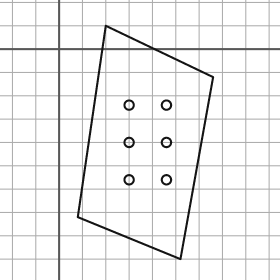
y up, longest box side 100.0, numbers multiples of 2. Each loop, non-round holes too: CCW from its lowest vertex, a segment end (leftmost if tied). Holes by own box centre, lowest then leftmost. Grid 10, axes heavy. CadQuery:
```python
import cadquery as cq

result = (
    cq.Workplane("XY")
    .moveTo(52.0, -90.0)
    .lineTo(66.0, -12.0)
    .lineTo(20.0, 10.0)
    .lineTo(8.0, -72.0)
    .close()
    .moveTo(30.0, -56.0)
    .circle(2.0)
    .moveTo(46.0, -56.0)
    .circle(2.0)
    .moveTo(30.0, -40.0)
    .circle(2.0)
    .moveTo(46.0, -40.0)
    .circle(2.0)
    .moveTo(30.0, -24.0)
    .circle(2.0)
    .moveTo(46.0, -24.0)
    .circle(2.0)
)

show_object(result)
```